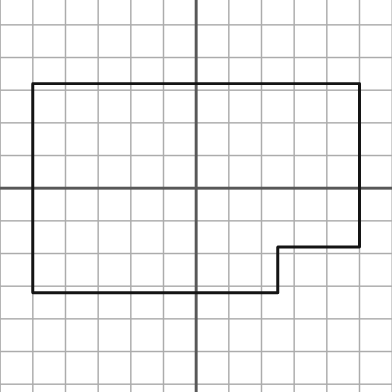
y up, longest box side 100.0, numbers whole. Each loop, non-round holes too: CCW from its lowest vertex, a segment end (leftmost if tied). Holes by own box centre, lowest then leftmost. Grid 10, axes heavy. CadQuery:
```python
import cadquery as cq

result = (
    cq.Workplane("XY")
    .moveTo(-50.0, -32.0)
    .lineTo(25.0, -32.0)
    .lineTo(25.0, -18.0)
    .lineTo(50.0, -18.0)
    .lineTo(50.0, 32.0)
    .lineTo(-50.0, 32.0)
    .close()
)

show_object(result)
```